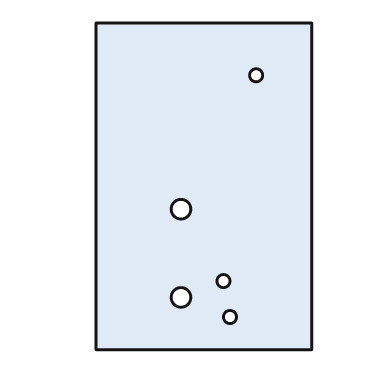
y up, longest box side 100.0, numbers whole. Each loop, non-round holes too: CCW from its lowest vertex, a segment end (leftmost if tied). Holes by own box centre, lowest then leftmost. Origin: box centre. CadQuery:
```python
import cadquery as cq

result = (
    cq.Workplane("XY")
    .moveTo(-33.0, -50.0)
    .lineTo(33.0, -50.0)
    .lineTo(33.0, 50.0)
    .lineTo(-33.0, 50.0)
    .close()
    .moveTo(8.0, -40.0)
    .circle(2.0)
    .moveTo(-7.0, -34.0)
    .circle(3.0)
    .moveTo(6.0, -29.0)
    .circle(2.0)
    .moveTo(-7.0, -7.0)
    .circle(3.0)
    .moveTo(16.0, 34.0)
    .circle(2.0)
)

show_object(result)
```